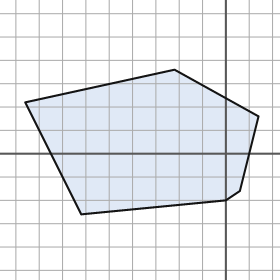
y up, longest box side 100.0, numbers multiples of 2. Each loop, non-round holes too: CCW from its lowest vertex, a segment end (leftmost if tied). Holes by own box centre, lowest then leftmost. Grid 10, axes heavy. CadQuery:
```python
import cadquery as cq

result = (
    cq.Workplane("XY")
    .moveTo(-62.0, -26.0)
    .lineTo(0.0, -20.0)
    .lineTo(6.0, -16.0)
    .lineTo(14.0, 16.0)
    .lineTo(-22.0, 36.0)
    .lineTo(-86.0, 22.0)
    .close()
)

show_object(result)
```